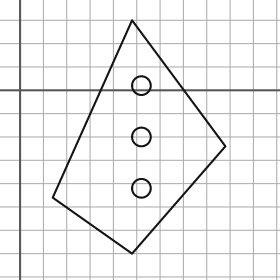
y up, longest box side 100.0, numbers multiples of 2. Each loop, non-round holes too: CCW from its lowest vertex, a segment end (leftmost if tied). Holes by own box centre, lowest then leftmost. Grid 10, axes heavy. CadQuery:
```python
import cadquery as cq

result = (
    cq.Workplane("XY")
    .moveTo(48.0, -70.0)
    .lineTo(88.0, -24.0)
    .lineTo(48.0, 30.0)
    .lineTo(14.0, -46.0)
    .close()
    .moveTo(52.0, -42.0)
    .circle(4.0)
    .moveTo(52.0, -20.0)
    .circle(4.0)
    .moveTo(52.0, 2.0)
    .circle(4.0)
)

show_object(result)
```